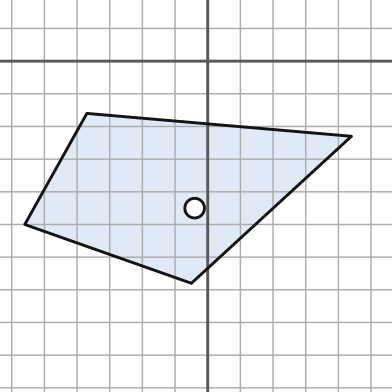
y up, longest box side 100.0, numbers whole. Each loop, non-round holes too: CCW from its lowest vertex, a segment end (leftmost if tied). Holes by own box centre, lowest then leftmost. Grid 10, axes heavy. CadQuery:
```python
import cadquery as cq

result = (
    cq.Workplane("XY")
    .moveTo(-5.0, -68.0)
    .lineTo(44.0, -23.0)
    .lineTo(-37.0, -16.0)
    .lineTo(-56.0, -50.0)
    .close()
    .moveTo(-4.0, -45.0)
    .circle(3.0)
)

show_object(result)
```